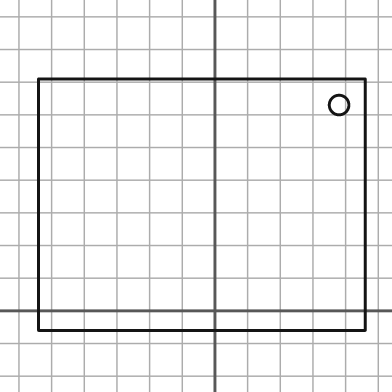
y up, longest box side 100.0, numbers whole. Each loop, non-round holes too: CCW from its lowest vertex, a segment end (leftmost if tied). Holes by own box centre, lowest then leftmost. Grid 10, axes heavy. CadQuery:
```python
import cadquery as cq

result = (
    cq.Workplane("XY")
    .moveTo(-54.0, -6.0)
    .lineTo(46.0, -6.0)
    .lineTo(46.0, 71.0)
    .lineTo(-54.0, 71.0)
    .close()
    .moveTo(38.0, 63.0)
    .circle(3.0)
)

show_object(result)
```